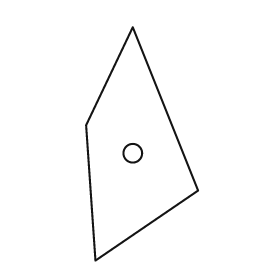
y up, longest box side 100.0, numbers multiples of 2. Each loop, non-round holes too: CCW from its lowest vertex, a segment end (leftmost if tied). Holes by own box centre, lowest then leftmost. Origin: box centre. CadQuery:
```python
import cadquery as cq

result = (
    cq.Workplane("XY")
    .moveTo(-20.0, -50.0)
    .lineTo(24.0, -20.0)
    .lineTo(-4.0, 50.0)
    .lineTo(-24.0, 8.0)
    .close()
    .moveTo(-4.0, -4.0)
    .circle(4.0)
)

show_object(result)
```